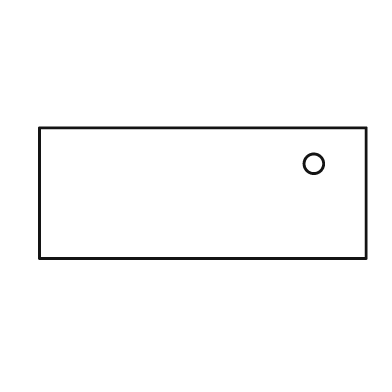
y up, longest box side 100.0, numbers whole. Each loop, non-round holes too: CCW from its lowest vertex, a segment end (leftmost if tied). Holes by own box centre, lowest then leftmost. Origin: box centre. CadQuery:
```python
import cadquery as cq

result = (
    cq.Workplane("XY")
    .moveTo(-50.0, -20.0)
    .lineTo(50.0, -20.0)
    .lineTo(50.0, 20.0)
    .lineTo(-50.0, 20.0)
    .close()
    .moveTo(34.0, 9.0)
    .circle(3.0)
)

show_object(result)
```